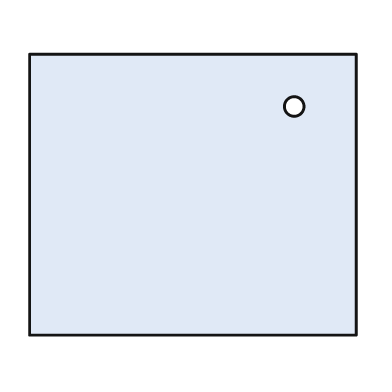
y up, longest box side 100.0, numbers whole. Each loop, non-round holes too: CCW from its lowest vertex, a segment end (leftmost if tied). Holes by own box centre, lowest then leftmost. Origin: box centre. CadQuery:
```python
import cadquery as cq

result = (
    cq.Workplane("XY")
    .moveTo(-50.0, -43.0)
    .lineTo(50.0, -43.0)
    .lineTo(50.0, 43.0)
    .lineTo(-50.0, 43.0)
    .close()
    .moveTo(31.0, 27.0)
    .circle(3.0)
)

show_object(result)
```